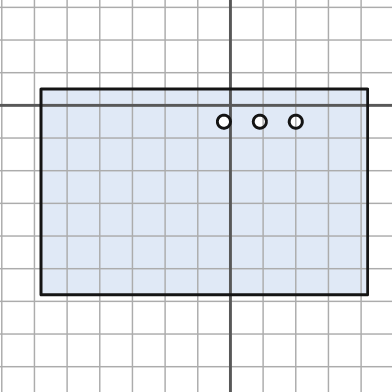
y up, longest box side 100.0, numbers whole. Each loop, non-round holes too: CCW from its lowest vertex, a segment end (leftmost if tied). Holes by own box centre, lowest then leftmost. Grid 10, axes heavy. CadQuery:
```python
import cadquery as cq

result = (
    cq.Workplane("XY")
    .moveTo(-58.0, -58.0)
    .lineTo(42.0, -58.0)
    .lineTo(42.0, 5.0)
    .lineTo(-58.0, 5.0)
    .close()
    .moveTo(-2.0, -5.0)
    .circle(2.0)
    .moveTo(9.0, -5.0)
    .circle(2.0)
    .moveTo(20.0, -5.0)
    .circle(2.0)
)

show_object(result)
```